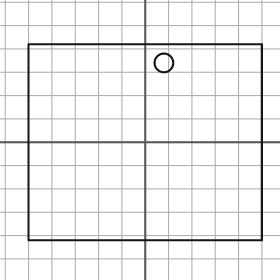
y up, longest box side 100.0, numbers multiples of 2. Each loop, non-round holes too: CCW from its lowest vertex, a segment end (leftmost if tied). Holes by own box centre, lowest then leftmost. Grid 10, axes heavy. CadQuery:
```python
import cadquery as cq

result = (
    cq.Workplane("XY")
    .moveTo(-50.0, -42.0)
    .lineTo(50.0, -42.0)
    .lineTo(50.0, 42.0)
    .lineTo(-50.0, 42.0)
    .close()
    .moveTo(8.0, 34.0)
    .circle(4.0)
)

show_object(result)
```